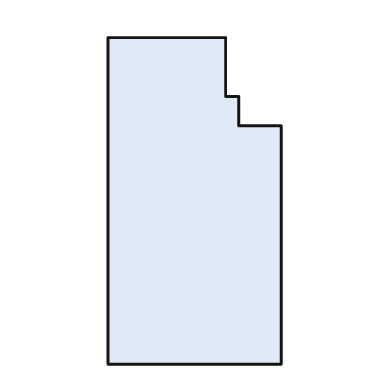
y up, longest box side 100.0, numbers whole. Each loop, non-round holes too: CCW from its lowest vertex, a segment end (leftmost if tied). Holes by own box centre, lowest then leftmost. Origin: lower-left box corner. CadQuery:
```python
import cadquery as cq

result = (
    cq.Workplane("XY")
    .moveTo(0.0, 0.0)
    .lineTo(53.0, 0.0)
    .lineTo(53.0, 73.0)
    .lineTo(40.0, 73.0)
    .lineTo(40.0, 82.0)
    .lineTo(36.0, 82.0)
    .lineTo(36.0, 100.0)
    .lineTo(0.0, 100.0)
    .close()
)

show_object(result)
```